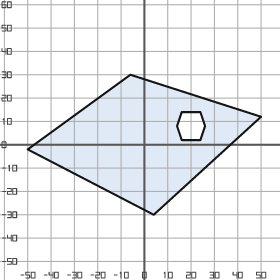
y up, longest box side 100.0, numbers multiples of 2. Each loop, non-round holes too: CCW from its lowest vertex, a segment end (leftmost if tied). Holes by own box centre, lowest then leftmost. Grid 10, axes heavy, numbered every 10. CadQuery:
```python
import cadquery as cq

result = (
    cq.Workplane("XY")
    .moveTo(4.0, -30.0)
    .lineTo(50.0, 12.0)
    .lineTo(-6.0, 30.0)
    .lineTo(-50.0, -2.0)
    .close()
    .moveTo(16.0, 2.0)
    .lineTo(24.0, 2.0)
    .lineTo(26.0, 8.0)
    .lineTo(24.0, 14.0)
    .lineTo(16.0, 14.0)
    .lineTo(14.0, 8.0)
    .close()
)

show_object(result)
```